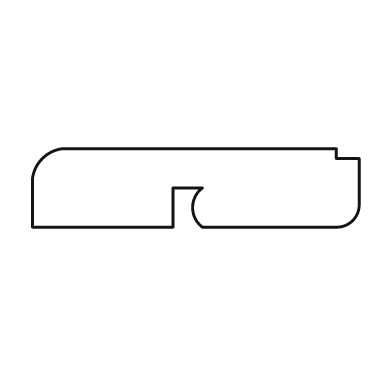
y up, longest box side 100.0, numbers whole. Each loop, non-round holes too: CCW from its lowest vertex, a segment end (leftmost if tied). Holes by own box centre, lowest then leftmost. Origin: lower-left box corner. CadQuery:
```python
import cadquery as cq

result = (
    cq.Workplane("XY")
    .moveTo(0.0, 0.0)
    .lineTo(43.0, 0.0)
    .lineTo(43.0, 12.0)
    .lineTo(52.0, 12.0)
    .threePointArc((49.0, 6.0), (52.0, 0.0))
    .lineTo(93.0, 0.0)
    .threePointArc((98.0, 2.0), (100.0, 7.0))
    .lineTo(100.0, 21.0)
    .lineTo(93.0, 21.0)
    .lineTo(93.0, 24.0)
    .lineTo(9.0, 24.0)
    .threePointArc((3.0, 21.0), (0.0, 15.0))
    .close()
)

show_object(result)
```